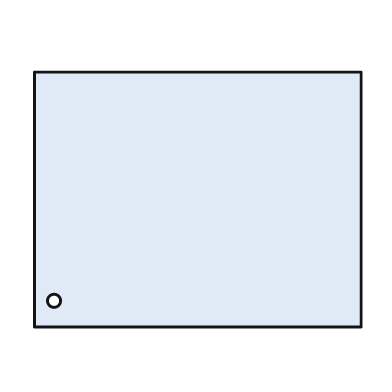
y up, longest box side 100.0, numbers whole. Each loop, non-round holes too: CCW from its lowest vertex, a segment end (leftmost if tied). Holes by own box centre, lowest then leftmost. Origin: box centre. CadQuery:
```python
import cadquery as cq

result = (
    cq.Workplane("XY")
    .moveTo(-50.0, -39.0)
    .lineTo(50.0, -39.0)
    .lineTo(50.0, 39.0)
    .lineTo(-50.0, 39.0)
    .close()
    .moveTo(-44.0, -31.0)
    .circle(2.0)
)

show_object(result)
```